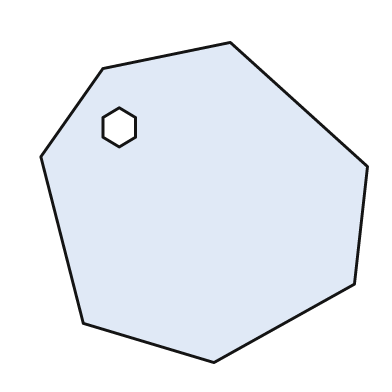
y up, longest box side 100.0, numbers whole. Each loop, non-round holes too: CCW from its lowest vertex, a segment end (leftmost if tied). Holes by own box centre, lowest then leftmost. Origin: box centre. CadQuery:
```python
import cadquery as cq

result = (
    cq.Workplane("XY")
    .moveTo(3.0, -49.0)
    .lineTo(46.0, -25.0)
    .lineTo(50.0, 11.0)
    .lineTo(8.0, 49.0)
    .lineTo(-31.0, 41.0)
    .lineTo(-50.0, 14.0)
    .lineTo(-37.0, -37.0)
    .close()
    .moveTo(-26.0, 17.0)
    .lineTo(-21.0, 20.0)
    .lineTo(-21.0, 26.0)
    .lineTo(-26.0, 29.0)
    .lineTo(-31.0, 26.0)
    .lineTo(-31.0, 20.0)
    .close()
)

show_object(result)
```